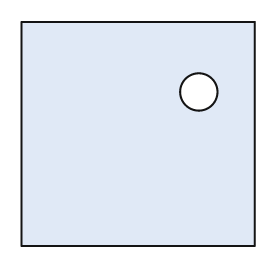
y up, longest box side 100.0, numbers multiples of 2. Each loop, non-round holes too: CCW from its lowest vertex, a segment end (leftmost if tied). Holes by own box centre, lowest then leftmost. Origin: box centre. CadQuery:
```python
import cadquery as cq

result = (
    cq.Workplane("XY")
    .moveTo(-50.0, -48.0)
    .lineTo(50.0, -48.0)
    .lineTo(50.0, 48.0)
    .lineTo(-50.0, 48.0)
    .close()
    .moveTo(26.0, 18.0)
    .circle(8.0)
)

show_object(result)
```